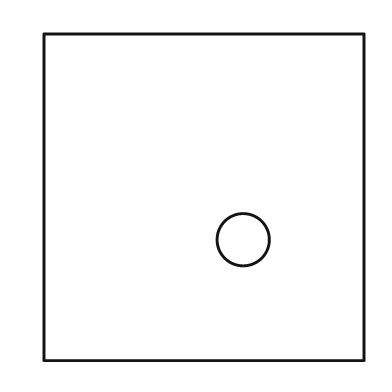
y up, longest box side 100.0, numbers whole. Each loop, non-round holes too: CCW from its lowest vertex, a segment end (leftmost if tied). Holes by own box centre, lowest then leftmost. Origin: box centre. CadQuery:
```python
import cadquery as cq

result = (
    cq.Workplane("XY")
    .moveTo(-49.0, -50.0)
    .lineTo(49.0, -50.0)
    .lineTo(49.0, 50.0)
    .lineTo(-49.0, 50.0)
    .close()
    .moveTo(12.0, -13.0)
    .circle(8.0)
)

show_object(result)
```